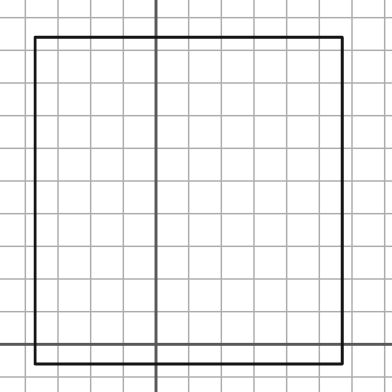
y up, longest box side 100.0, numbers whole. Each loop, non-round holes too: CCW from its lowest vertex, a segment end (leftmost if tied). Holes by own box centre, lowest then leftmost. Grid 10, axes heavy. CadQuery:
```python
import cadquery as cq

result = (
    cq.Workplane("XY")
    .moveTo(-37.0, -6.0)
    .lineTo(57.0, -6.0)
    .lineTo(57.0, 94.0)
    .lineTo(-37.0, 94.0)
    .close()
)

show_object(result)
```